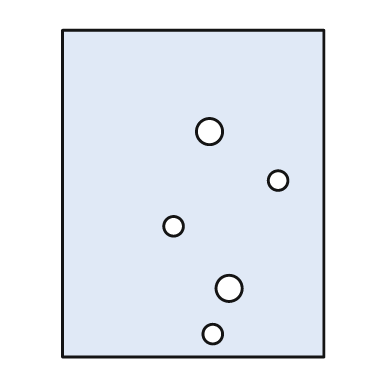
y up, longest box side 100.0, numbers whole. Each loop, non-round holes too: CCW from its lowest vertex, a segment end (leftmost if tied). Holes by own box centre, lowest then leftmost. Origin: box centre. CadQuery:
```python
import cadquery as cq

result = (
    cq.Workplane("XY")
    .moveTo(-40.0, -50.0)
    .lineTo(40.0, -50.0)
    .lineTo(40.0, 50.0)
    .lineTo(-40.0, 50.0)
    .close()
    .moveTo(6.0, -43.0)
    .circle(3.0)
    .moveTo(11.0, -29.0)
    .circle(4.0)
    .moveTo(-6.0, -10.0)
    .circle(3.0)
    .moveTo(26.0, 4.0)
    .circle(3.0)
    .moveTo(5.0, 19.0)
    .circle(4.0)
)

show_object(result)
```